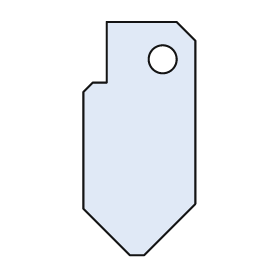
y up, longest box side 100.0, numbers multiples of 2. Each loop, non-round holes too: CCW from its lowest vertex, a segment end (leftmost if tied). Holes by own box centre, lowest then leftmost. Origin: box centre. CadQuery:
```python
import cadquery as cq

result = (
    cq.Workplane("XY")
    .moveTo(-4.0, -50.0)
    .lineTo(2.0, -50.0)
    .lineTo(24.0, -28.0)
    .lineTo(24.0, 42.0)
    .lineTo(16.0, 50.0)
    .lineTo(-14.0, 50.0)
    .lineTo(-14.0, 24.0)
    .lineTo(-20.0, 24.0)
    .lineTo(-24.0, 20.0)
    .lineTo(-24.0, -30.0)
    .close()
    .moveTo(10.0, 34.0)
    .circle(6.0)
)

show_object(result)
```